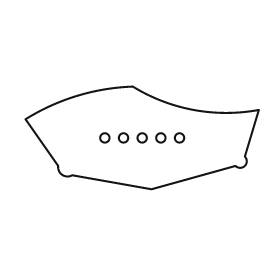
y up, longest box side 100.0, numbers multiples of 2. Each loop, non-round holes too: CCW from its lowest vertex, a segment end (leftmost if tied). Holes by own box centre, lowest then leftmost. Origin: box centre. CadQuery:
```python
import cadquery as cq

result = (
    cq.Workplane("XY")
    .moveTo(4.0, -22.0)
    .lineTo(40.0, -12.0)
    .threePointArc((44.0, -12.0), (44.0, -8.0))
    .lineTo(50.0, 12.0)
    .threePointArc((22.0, 12.0), (-4.0, 22.0))
    .threePointArc((-28.0, 18.0), (-50.0, 8.0))
    .lineTo(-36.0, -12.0)
    .threePointArc((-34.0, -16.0), (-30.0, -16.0))
    .close()
    .moveTo(-16.0, 0.0)
    .circle(2.0)
    .moveTo(-8.0, 0.0)
    .circle(2.0)
    .moveTo(0.0, 0.0)
    .circle(2.0)
    .moveTo(8.0, 0.0)
    .circle(2.0)
    .moveTo(16.0, 0.0)
    .circle(2.0)
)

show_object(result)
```